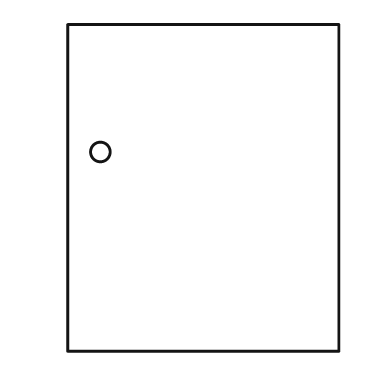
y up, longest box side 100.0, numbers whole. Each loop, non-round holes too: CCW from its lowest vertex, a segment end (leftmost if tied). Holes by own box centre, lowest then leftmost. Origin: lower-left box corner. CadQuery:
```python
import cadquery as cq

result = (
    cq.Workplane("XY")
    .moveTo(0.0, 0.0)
    .lineTo(83.0, 0.0)
    .lineTo(83.0, 100.0)
    .lineTo(0.0, 100.0)
    .close()
    .moveTo(10.0, 61.0)
    .circle(3.0)
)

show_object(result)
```